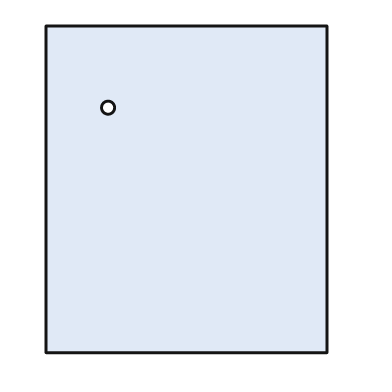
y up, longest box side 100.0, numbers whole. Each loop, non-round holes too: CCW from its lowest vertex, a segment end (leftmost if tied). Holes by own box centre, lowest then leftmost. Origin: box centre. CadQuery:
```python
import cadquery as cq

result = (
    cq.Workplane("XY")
    .moveTo(-43.0, -50.0)
    .lineTo(43.0, -50.0)
    .lineTo(43.0, 50.0)
    .lineTo(-43.0, 50.0)
    .close()
    .moveTo(-24.0, 25.0)
    .circle(2.0)
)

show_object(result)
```